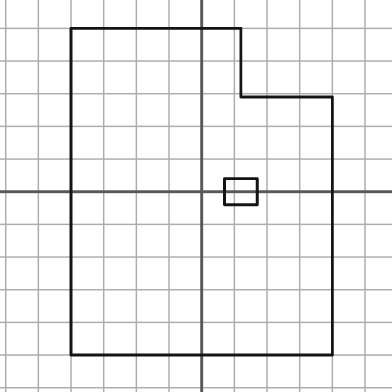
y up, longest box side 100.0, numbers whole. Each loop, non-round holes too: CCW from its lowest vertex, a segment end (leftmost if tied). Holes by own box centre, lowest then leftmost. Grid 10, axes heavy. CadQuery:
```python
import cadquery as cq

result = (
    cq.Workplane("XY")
    .moveTo(-40.0, -50.0)
    .lineTo(40.0, -50.0)
    .lineTo(40.0, 29.0)
    .lineTo(12.0, 29.0)
    .lineTo(12.0, 50.0)
    .lineTo(-40.0, 50.0)
    .close()
    .moveTo(7.0, -4.0)
    .lineTo(17.0, -4.0)
    .lineTo(17.0, 4.0)
    .lineTo(7.0, 4.0)
    .close()
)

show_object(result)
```